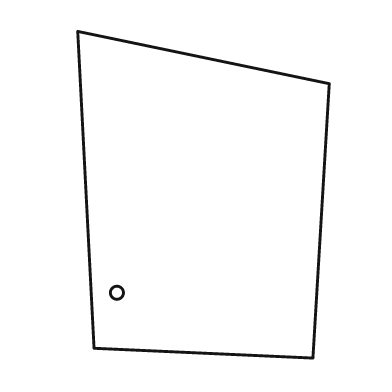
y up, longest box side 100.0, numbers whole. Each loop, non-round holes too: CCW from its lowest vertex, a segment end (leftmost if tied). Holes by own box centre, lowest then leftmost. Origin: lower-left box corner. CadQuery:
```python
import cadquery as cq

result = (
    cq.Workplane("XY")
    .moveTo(72.0, 0.0)
    .lineTo(77.0, 84.0)
    .lineTo(0.0, 100.0)
    .lineTo(5.0, 3.0)
    .close()
    .moveTo(12.0, 20.0)
    .circle(2.0)
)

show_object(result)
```